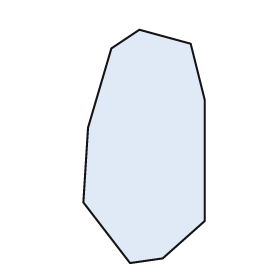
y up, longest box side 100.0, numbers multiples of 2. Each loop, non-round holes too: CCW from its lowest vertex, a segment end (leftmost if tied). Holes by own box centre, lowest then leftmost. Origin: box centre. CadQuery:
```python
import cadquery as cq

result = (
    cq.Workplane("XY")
    .moveTo(-6.0, -50.0)
    .lineTo(8.0, -48.0)
    .lineTo(26.0, -32.0)
    .lineTo(26.0, 20.0)
    .lineTo(20.0, 44.0)
    .lineTo(-2.0, 50.0)
    .lineTo(-14.0, 42.0)
    .lineTo(-24.0, 8.0)
    .lineTo(-26.0, -24.0)
    .close()
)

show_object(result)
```